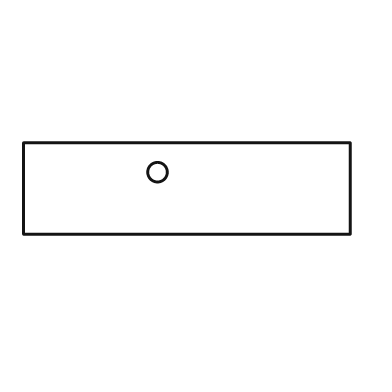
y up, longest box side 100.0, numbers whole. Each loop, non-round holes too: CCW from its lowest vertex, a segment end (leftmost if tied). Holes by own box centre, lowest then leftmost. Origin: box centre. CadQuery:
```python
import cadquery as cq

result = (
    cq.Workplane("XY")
    .moveTo(-50.0, -14.0)
    .lineTo(50.0, -14.0)
    .lineTo(50.0, 14.0)
    .lineTo(-50.0, 14.0)
    .close()
    .moveTo(-9.0, 5.0)
    .circle(3.0)
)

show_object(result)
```